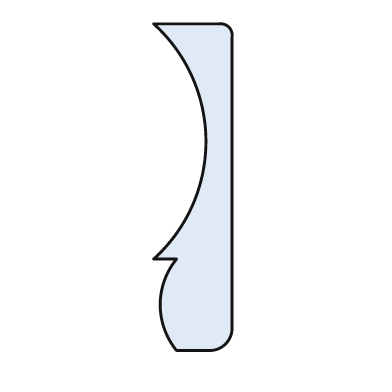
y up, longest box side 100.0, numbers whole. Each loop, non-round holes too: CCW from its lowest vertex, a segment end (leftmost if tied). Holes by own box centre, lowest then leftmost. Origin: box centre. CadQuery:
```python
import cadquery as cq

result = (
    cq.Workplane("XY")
    .moveTo(-5.0, -50.0)
    .lineTo(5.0, -50.0)
    .threePointArc((10.0, -48.0), (12.0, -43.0))
    .lineTo(12.0, 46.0)
    .threePointArc((11.0, 49.0), (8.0, 50.0))
    .lineTo(-12.0, 50.0)
    .threePointArc((4.0, 14.0), (-12.0, -22.0))
    .lineTo(-5.0, -22.0)
    .threePointArc((-10.0, -36.0), (-5.0, -50.0))
    .close()
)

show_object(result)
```